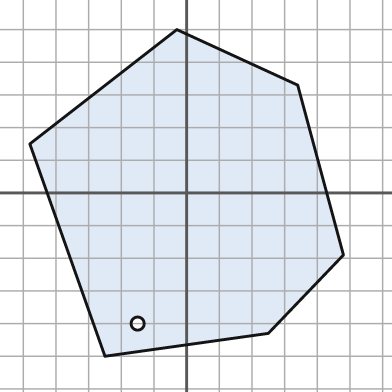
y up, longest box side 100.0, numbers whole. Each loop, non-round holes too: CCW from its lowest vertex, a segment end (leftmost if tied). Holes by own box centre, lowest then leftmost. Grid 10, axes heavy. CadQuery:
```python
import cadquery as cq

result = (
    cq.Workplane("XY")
    .moveTo(-25.0, -50.0)
    .lineTo(25.0, -43.0)
    .lineTo(48.0, -19.0)
    .lineTo(34.0, 33.0)
    .lineTo(-3.0, 50.0)
    .lineTo(-48.0, 15.0)
    .close()
    .moveTo(-15.0, -40.0)
    .circle(2.0)
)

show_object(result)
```